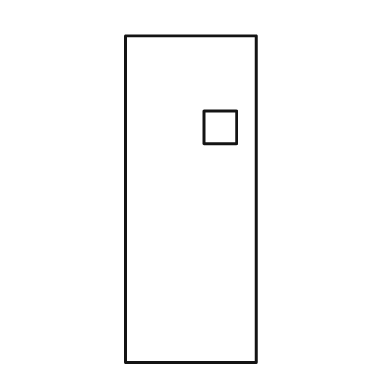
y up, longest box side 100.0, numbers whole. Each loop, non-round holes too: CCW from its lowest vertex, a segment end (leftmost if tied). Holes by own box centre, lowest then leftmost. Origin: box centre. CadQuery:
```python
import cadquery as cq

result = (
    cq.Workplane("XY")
    .moveTo(-20.0, -50.0)
    .lineTo(20.0, -50.0)
    .lineTo(20.0, 50.0)
    .lineTo(-20.0, 50.0)
    .close()
    .moveTo(4.0, 17.0)
    .lineTo(14.0, 17.0)
    .lineTo(14.0, 27.0)
    .lineTo(4.0, 27.0)
    .close()
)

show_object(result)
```